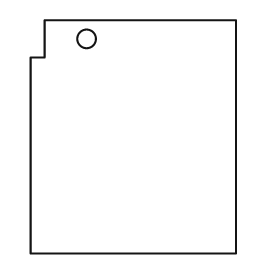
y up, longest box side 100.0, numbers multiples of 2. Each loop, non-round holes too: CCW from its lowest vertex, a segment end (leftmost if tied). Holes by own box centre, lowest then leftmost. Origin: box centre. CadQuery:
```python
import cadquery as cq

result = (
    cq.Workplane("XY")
    .moveTo(-44.0, -50.0)
    .lineTo(44.0, -50.0)
    .lineTo(44.0, 50.0)
    .lineTo(-38.0, 50.0)
    .lineTo(-38.0, 34.0)
    .lineTo(-44.0, 34.0)
    .close()
    .moveTo(-20.0, 42.0)
    .circle(4.0)
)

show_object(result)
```